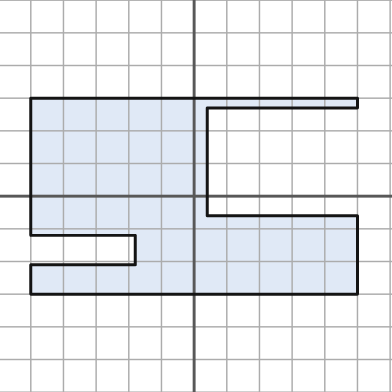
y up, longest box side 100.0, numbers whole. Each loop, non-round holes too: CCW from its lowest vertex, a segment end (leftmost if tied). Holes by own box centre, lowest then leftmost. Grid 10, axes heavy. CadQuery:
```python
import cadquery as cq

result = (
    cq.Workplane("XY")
    .moveTo(-50.0, -30.0)
    .lineTo(50.0, -30.0)
    .lineTo(50.0, -6.0)
    .lineTo(4.0, -6.0)
    .lineTo(4.0, 27.0)
    .lineTo(50.0, 27.0)
    .lineTo(50.0, 30.0)
    .lineTo(-50.0, 30.0)
    .lineTo(-50.0, -12.0)
    .lineTo(-18.0, -12.0)
    .lineTo(-18.0, -21.0)
    .lineTo(-50.0, -21.0)
    .close()
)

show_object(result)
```